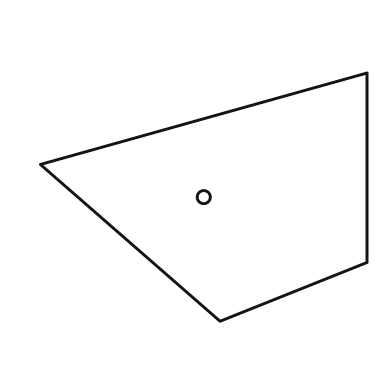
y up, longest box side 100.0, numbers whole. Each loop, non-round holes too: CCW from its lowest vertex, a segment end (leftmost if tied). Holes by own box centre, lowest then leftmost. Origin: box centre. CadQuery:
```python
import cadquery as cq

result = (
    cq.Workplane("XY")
    .moveTo(5.0, -38.0)
    .lineTo(50.0, -20.0)
    .lineTo(50.0, 38.0)
    .lineTo(-50.0, 10.0)
    .close()
    .moveTo(0.0, 0.0)
    .circle(2.0)
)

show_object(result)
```